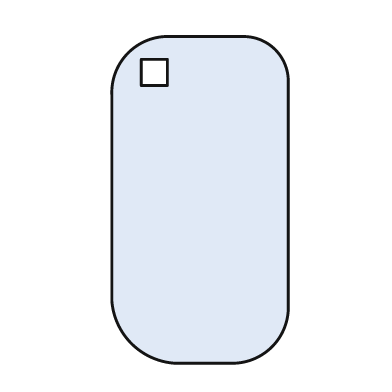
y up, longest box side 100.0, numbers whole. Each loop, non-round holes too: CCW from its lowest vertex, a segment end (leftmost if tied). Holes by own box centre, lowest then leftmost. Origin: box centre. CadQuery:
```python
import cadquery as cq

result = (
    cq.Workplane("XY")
    .moveTo(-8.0, -50.0)
    .lineTo(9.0, -50.0)
    .threePointArc((22.0, -45.0), (27.0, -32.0))
    .lineTo(27.0, 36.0)
    .threePointArc((23.0, 46.0), (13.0, 50.0))
    .lineTo(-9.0, 50.0)
    .threePointArc((-22.0, 45.0), (-27.0, 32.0))
    .lineTo(-27.0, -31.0)
    .threePointArc((-21.0, -44.0), (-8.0, -50.0))
    .close()
    .moveTo(-18.0, 35.0)
    .lineTo(-10.0, 35.0)
    .lineTo(-10.0, 43.0)
    .lineTo(-18.0, 43.0)
    .close()
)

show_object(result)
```